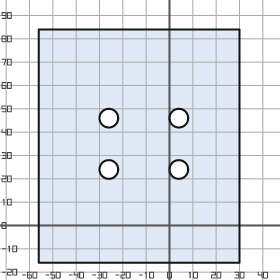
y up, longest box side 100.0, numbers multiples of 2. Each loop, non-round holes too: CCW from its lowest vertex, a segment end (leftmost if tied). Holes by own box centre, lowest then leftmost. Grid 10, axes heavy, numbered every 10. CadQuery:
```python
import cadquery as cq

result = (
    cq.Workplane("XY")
    .moveTo(-56.0, -16.0)
    .lineTo(30.0, -16.0)
    .lineTo(30.0, 84.0)
    .lineTo(-56.0, 84.0)
    .close()
    .moveTo(-26.0, 24.0)
    .circle(4.0)
    .moveTo(4.0, 24.0)
    .circle(4.0)
    .moveTo(-26.0, 46.0)
    .circle(4.0)
    .moveTo(4.0, 46.0)
    .circle(4.0)
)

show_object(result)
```